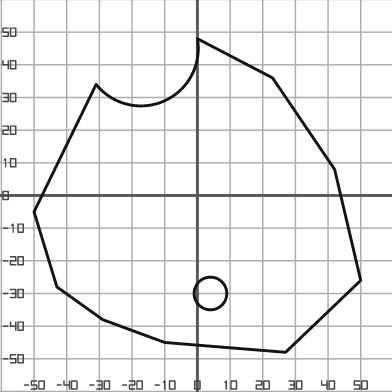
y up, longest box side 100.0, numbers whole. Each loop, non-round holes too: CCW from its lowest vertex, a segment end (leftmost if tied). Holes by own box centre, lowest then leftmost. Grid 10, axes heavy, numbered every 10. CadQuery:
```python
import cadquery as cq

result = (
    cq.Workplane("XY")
    .moveTo(27.0, -48.0)
    .lineTo(50.0, -26.0)
    .lineTo(42.0, 8.0)
    .lineTo(23.0, 36.0)
    .lineTo(0.0, 48.0)
    .threePointArc((-10.0, 29.0), (-31.0, 34.0))
    .lineTo(-50.0, -5.0)
    .lineTo(-43.0, -28.0)
    .lineTo(-29.0, -38.0)
    .lineTo(-10.0, -45.0)
    .close()
    .moveTo(4.0, -30.0)
    .circle(5.0)
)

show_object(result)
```